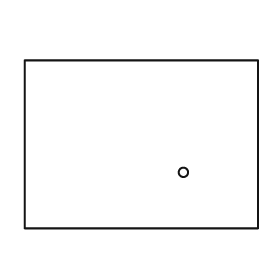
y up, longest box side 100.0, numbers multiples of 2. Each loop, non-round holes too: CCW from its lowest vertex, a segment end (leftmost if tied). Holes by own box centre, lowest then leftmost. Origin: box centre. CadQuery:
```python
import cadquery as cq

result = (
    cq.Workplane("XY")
    .moveTo(-50.0, -36.0)
    .lineTo(50.0, -36.0)
    .lineTo(50.0, 36.0)
    .lineTo(-50.0, 36.0)
    .close()
    .moveTo(18.0, -12.0)
    .circle(2.0)
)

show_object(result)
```